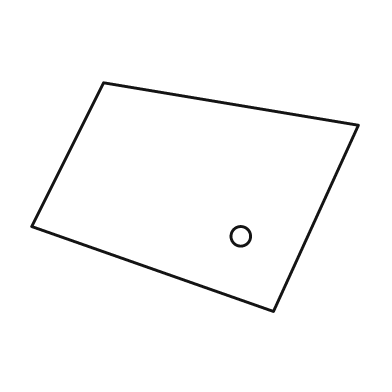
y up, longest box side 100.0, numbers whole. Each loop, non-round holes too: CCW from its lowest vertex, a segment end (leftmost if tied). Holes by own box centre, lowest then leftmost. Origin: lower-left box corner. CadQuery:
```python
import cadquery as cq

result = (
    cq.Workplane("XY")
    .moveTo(74.0, 0.0)
    .lineTo(100.0, 57.0)
    .lineTo(22.0, 70.0)
    .lineTo(0.0, 26.0)
    .close()
    .moveTo(64.0, 23.0)
    .circle(3.0)
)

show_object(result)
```